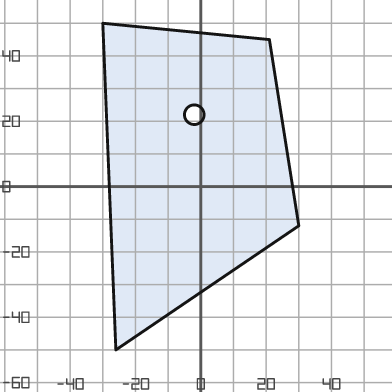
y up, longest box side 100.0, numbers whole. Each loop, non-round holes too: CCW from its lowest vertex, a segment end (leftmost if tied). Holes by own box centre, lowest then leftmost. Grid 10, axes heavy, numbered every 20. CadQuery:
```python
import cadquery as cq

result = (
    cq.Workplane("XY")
    .moveTo(-26.0, -50.0)
    .lineTo(30.0, -12.0)
    .lineTo(21.0, 45.0)
    .lineTo(-30.0, 50.0)
    .close()
    .moveTo(-2.0, 22.0)
    .circle(3.0)
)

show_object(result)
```